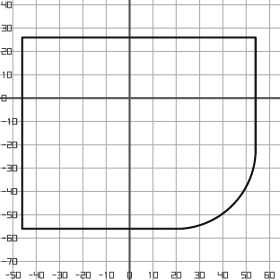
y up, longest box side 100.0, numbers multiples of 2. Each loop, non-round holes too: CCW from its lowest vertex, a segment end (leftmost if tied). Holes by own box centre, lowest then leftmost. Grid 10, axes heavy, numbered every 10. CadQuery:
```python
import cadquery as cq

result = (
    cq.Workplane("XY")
    .moveTo(-46.0, -56.0)
    .lineTo(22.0, -56.0)
    .threePointArc((44.0, -46.0), (54.0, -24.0))
    .lineTo(54.0, 26.0)
    .lineTo(-46.0, 26.0)
    .close()
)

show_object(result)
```